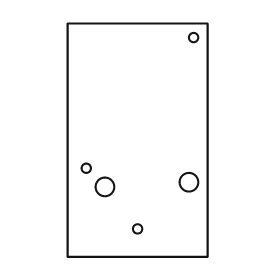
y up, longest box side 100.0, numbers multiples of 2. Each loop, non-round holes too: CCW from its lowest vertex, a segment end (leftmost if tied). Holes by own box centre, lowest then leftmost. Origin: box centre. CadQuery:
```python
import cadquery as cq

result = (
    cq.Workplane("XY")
    .moveTo(-30.0, -50.0)
    .lineTo(30.0, -50.0)
    .lineTo(30.0, 50.0)
    .lineTo(-30.0, 50.0)
    .close()
    .moveTo(0.0, -38.0)
    .circle(2.0)
    .moveTo(-14.0, -20.0)
    .circle(4.0)
    .moveTo(22.0, -18.0)
    .circle(4.0)
    .moveTo(-22.0, -12.0)
    .circle(2.0)
    .moveTo(24.0, 44.0)
    .circle(2.0)
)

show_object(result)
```